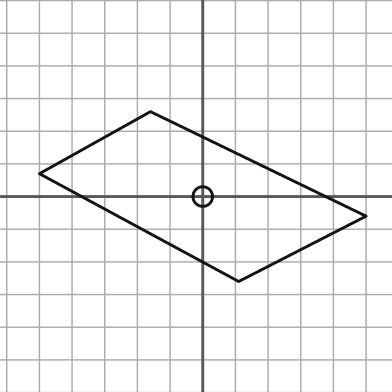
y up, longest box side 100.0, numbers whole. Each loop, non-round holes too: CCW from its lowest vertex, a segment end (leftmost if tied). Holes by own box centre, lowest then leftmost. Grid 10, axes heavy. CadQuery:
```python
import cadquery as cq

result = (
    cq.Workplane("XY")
    .moveTo(11.0, -26.0)
    .lineTo(50.0, -6.0)
    .lineTo(-16.0, 26.0)
    .lineTo(-50.0, 7.0)
    .close()
    .moveTo(0.0, 0.0)
    .circle(3.0)
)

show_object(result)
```